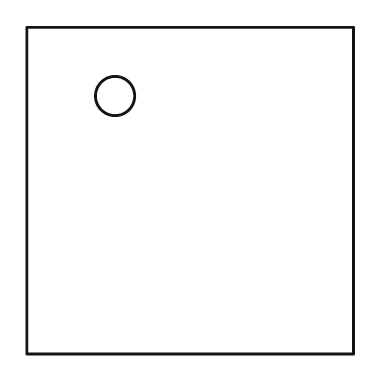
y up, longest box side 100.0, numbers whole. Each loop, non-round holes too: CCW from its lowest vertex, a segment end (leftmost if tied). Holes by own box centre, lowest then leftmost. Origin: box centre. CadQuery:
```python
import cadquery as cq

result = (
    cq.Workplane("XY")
    .moveTo(-50.0, -50.0)
    .lineTo(50.0, -50.0)
    .lineTo(50.0, 50.0)
    .lineTo(-50.0, 50.0)
    .close()
    .moveTo(-23.0, 29.0)
    .circle(6.0)
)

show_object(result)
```